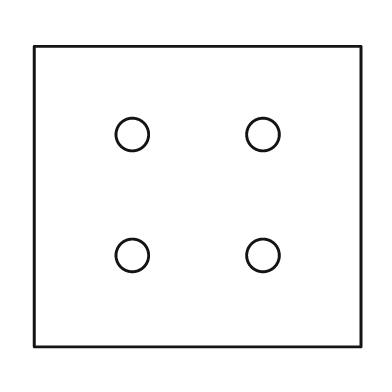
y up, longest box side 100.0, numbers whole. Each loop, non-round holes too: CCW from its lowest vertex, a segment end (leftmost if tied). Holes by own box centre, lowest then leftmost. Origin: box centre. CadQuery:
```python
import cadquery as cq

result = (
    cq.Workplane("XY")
    .moveTo(-50.0, -46.0)
    .lineTo(50.0, -46.0)
    .lineTo(50.0, 46.0)
    .lineTo(-50.0, 46.0)
    .close()
    .moveTo(-20.0, -18.0)
    .circle(5.0)
    .moveTo(20.0, -18.0)
    .circle(5.0)
    .moveTo(-20.0, 19.0)
    .circle(5.0)
    .moveTo(20.0, 19.0)
    .circle(5.0)
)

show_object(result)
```